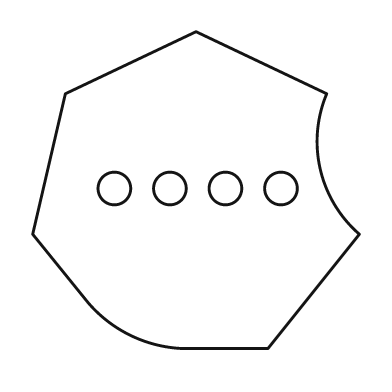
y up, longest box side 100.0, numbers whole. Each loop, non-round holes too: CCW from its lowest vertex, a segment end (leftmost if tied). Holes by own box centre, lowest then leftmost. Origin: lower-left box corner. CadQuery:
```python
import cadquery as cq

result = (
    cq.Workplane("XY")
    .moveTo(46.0, 0.0)
    .lineTo(72.0, 0.0)
    .lineTo(100.0, 35.0)
    .threePointArc((88.0, 55.0), (90.0, 78.0))
    .lineTo(50.0, 97.0)
    .lineTo(10.0, 78.0)
    .lineTo(0.0, 35.0)
    .lineTo(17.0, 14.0)
    .threePointArc((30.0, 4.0), (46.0, 0.0))
    .close()
    .moveTo(25.0, 49.0)
    .circle(5.0)
    .moveTo(42.0, 49.0)
    .circle(5.0)
    .moveTo(59.0, 49.0)
    .circle(5.0)
    .moveTo(76.0, 49.0)
    .circle(5.0)
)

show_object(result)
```